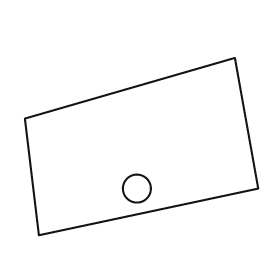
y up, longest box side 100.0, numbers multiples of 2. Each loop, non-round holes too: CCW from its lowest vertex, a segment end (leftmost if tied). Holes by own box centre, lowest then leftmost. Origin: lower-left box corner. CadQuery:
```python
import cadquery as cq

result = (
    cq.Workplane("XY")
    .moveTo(6.0, 0.0)
    .lineTo(100.0, 20.0)
    .lineTo(90.0, 76.0)
    .lineTo(0.0, 50.0)
    .close()
    .moveTo(48.0, 20.0)
    .circle(6.0)
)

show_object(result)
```